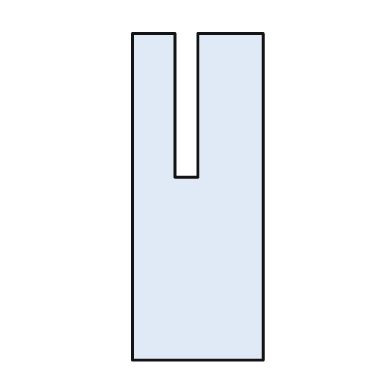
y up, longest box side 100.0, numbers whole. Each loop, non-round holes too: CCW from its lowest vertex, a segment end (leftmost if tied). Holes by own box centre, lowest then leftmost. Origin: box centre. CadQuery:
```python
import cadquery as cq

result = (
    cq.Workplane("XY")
    .moveTo(-20.0, -50.0)
    .lineTo(20.0, -50.0)
    .lineTo(20.0, 50.0)
    .lineTo(0.0, 50.0)
    .lineTo(0.0, 6.0)
    .lineTo(-7.0, 6.0)
    .lineTo(-7.0, 50.0)
    .lineTo(-20.0, 50.0)
    .close()
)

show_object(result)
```